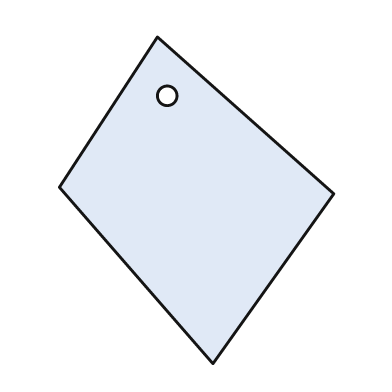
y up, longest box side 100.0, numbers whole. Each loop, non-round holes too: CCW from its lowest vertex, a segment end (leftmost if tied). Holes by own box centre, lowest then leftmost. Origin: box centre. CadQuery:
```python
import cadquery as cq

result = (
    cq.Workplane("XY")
    .moveTo(5.0, -50.0)
    .lineTo(42.0, 2.0)
    .lineTo(-12.0, 50.0)
    .lineTo(-42.0, 4.0)
    .close()
    .moveTo(-9.0, 32.0)
    .circle(3.0)
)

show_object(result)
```